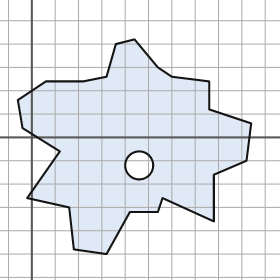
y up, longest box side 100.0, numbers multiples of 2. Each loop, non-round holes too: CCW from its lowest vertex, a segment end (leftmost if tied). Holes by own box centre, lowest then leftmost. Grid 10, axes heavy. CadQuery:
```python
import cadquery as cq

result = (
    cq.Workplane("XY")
    .moveTo(32.0, -50.0)
    .lineTo(42.0, -32.0)
    .lineTo(54.0, -32.0)
    .lineTo(56.0, -26.0)
    .lineTo(78.0, -36.0)
    .lineTo(78.0, -16.0)
    .lineTo(92.0, -10.0)
    .lineTo(94.0, 6.0)
    .lineTo(76.0, 12.0)
    .lineTo(76.0, 24.0)
    .lineTo(60.0, 26.0)
    .lineTo(54.0, 30.0)
    .lineTo(44.0, 42.0)
    .lineTo(36.0, 40.0)
    .lineTo(32.0, 26.0)
    .lineTo(22.0, 24.0)
    .lineTo(6.0, 24.0)
    .lineTo(-6.0, 16.0)
    .lineTo(-4.0, 4.0)
    .lineTo(12.0, -6.0)
    .lineTo(-2.0, -26.0)
    .lineTo(16.0, -30.0)
    .lineTo(18.0, -48.0)
    .close()
    .moveTo(46.0, -12.0)
    .circle(6.0)
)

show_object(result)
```